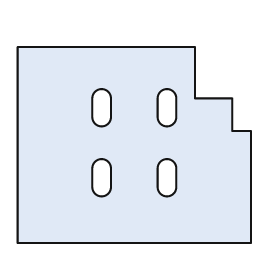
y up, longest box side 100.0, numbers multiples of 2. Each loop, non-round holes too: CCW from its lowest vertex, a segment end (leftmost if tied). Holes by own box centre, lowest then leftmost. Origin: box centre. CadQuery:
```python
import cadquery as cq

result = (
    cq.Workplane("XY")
    .moveTo(-50.0, -42.0)
    .lineTo(50.0, -42.0)
    .lineTo(50.0, 6.0)
    .lineTo(42.0, 6.0)
    .lineTo(42.0, 20.0)
    .lineTo(26.0, 20.0)
    .lineTo(26.0, 42.0)
    .lineTo(-50.0, 42.0)
    .close()
    .moveTo(-18.0, -18.0)
    .threePointArc((-14.0, -22.0), (-10.0, -18.0))
    .lineTo(-10.0, -10.0)
    .threePointArc((-14.0, -6.0), (-18.0, -10.0))
    .close()
    .moveTo(10.0, -18.0)
    .threePointArc((14.0, -22.0), (18.0, -18.0))
    .lineTo(18.0, -10.0)
    .threePointArc((14.0, -6.0), (10.0, -10.0))
    .close()
    .moveTo(-18.0, 12.0)
    .threePointArc((-14.0, 8.0), (-10.0, 12.0))
    .lineTo(-10.0, 20.0)
    .threePointArc((-14.0, 24.0), (-18.0, 20.0))
    .close()
    .moveTo(10.0, 12.0)
    .threePointArc((14.0, 8.0), (18.0, 12.0))
    .lineTo(18.0, 20.0)
    .threePointArc((14.0, 24.0), (10.0, 20.0))
    .close()
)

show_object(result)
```